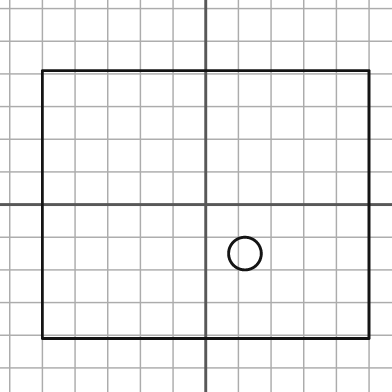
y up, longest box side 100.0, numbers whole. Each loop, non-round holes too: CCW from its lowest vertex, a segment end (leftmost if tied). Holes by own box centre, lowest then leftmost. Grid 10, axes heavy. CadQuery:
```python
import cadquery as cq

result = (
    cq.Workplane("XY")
    .moveTo(-50.0, -41.0)
    .lineTo(50.0, -41.0)
    .lineTo(50.0, 41.0)
    .lineTo(-50.0, 41.0)
    .close()
    .moveTo(12.0, -15.0)
    .circle(5.0)
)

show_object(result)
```